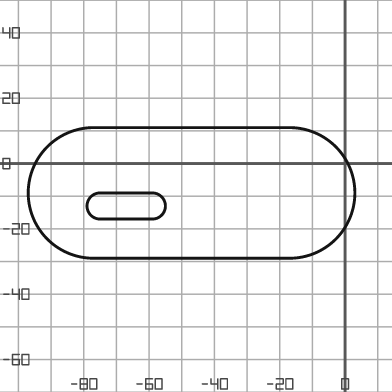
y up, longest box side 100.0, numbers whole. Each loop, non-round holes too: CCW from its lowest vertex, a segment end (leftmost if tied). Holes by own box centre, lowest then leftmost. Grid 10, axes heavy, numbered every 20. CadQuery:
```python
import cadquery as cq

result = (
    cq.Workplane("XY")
    .moveTo(-77.0, -29.0)
    .lineTo(-17.0, -29.0)
    .threePointArc((3.0, -9.0), (-17.0, 11.0))
    .lineTo(-77.0, 11.0)
    .threePointArc((-97.0, -9.0), (-77.0, -29.0))
    .close()
    .moveTo(-75.0, -17.0)
    .lineTo(-59.0, -17.0)
    .threePointArc((-55.0, -13.0), (-59.0, -9.0))
    .lineTo(-75.0, -9.0)
    .threePointArc((-79.0, -13.0), (-75.0, -17.0))
    .close()
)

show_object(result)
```